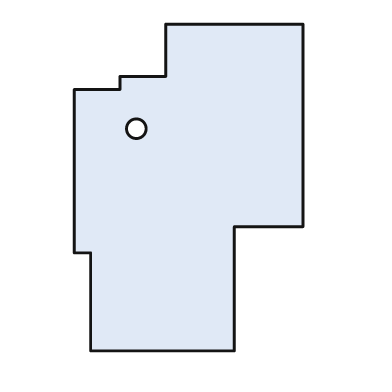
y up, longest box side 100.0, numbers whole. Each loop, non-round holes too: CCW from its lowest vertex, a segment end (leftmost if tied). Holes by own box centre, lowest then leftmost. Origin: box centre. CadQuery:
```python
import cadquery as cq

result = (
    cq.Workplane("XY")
    .moveTo(-30.0, -50.0)
    .lineTo(14.0, -50.0)
    .lineTo(14.0, -12.0)
    .lineTo(35.0, -12.0)
    .lineTo(35.0, 50.0)
    .lineTo(-7.0, 50.0)
    .lineTo(-7.0, 34.0)
    .lineTo(-21.0, 34.0)
    .lineTo(-21.0, 30.0)
    .lineTo(-35.0, 30.0)
    .lineTo(-35.0, -20.0)
    .lineTo(-30.0, -20.0)
    .close()
    .moveTo(-16.0, 18.0)
    .circle(3.0)
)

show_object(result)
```